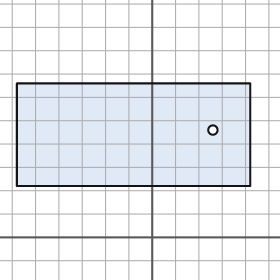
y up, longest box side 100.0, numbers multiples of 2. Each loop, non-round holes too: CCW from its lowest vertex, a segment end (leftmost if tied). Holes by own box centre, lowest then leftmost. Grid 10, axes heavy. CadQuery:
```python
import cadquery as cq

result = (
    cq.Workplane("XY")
    .moveTo(-58.0, 22.0)
    .lineTo(42.0, 22.0)
    .lineTo(42.0, 66.0)
    .lineTo(-58.0, 66.0)
    .close()
    .moveTo(26.0, 46.0)
    .circle(2.0)
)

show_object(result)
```